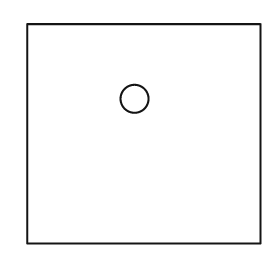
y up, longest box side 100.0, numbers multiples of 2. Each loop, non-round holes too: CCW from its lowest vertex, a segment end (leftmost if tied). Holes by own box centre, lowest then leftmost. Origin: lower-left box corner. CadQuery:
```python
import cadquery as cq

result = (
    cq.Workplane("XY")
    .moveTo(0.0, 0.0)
    .lineTo(100.0, 0.0)
    .lineTo(100.0, 94.0)
    .lineTo(0.0, 94.0)
    .close()
    .moveTo(46.0, 62.0)
    .circle(6.0)
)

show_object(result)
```